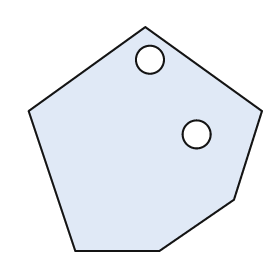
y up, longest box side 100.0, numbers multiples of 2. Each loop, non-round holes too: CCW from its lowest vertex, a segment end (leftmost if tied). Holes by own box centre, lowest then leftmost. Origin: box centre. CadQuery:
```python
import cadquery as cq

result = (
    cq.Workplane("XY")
    .moveTo(-30.0, -48.0)
    .lineTo(6.0, -48.0)
    .lineTo(38.0, -26.0)
    .lineTo(50.0, 12.0)
    .lineTo(0.0, 48.0)
    .lineTo(-50.0, 12.0)
    .close()
    .moveTo(22.0, 2.0)
    .circle(6.0)
    .moveTo(2.0, 34.0)
    .circle(6.0)
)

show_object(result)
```